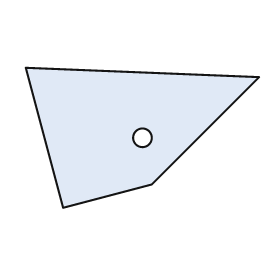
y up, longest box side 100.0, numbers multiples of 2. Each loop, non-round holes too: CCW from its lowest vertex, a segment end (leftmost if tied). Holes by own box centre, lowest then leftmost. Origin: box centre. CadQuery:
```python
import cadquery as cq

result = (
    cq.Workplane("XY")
    .moveTo(-34.0, -30.0)
    .lineTo(4.0, -20.0)
    .lineTo(50.0, 26.0)
    .lineTo(-50.0, 30.0)
    .close()
    .moveTo(0.0, 0.0)
    .circle(4.0)
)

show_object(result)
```